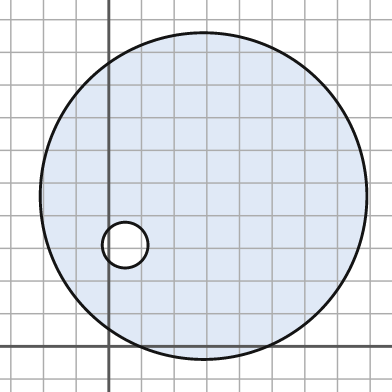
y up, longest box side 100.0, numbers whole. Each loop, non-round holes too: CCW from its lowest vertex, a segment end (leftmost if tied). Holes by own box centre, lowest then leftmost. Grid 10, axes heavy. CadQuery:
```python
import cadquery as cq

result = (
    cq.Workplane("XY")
    .moveTo(29.0, 46.0)
    .circle(50.0)
    .moveTo(5.0, 31.0)
    .circle(7.0)
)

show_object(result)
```